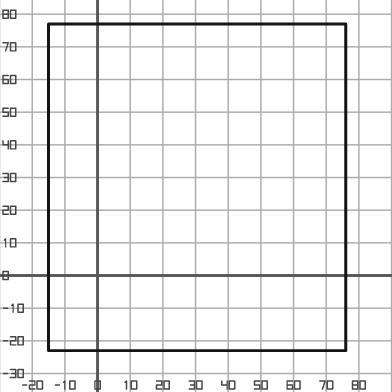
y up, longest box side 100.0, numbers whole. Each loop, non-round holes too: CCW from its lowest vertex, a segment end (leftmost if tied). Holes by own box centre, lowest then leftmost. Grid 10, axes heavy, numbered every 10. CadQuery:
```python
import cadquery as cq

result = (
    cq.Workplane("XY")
    .moveTo(-15.0, -23.0)
    .lineTo(76.0, -23.0)
    .lineTo(76.0, 77.0)
    .lineTo(-15.0, 77.0)
    .close()
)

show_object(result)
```